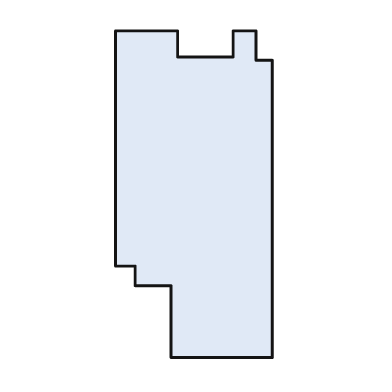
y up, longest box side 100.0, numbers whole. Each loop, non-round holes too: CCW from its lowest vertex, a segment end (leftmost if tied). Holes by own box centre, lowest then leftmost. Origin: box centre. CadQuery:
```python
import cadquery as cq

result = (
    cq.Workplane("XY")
    .moveTo(-7.0, -50.0)
    .lineTo(24.0, -50.0)
    .lineTo(24.0, 41.0)
    .lineTo(19.0, 41.0)
    .lineTo(19.0, 50.0)
    .lineTo(12.0, 50.0)
    .lineTo(12.0, 42.0)
    .lineTo(-5.0, 42.0)
    .lineTo(-5.0, 50.0)
    .lineTo(-24.0, 50.0)
    .lineTo(-24.0, -22.0)
    .lineTo(-18.0, -22.0)
    .lineTo(-18.0, -28.0)
    .lineTo(-7.0, -28.0)
    .close()
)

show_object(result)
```